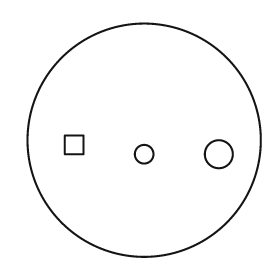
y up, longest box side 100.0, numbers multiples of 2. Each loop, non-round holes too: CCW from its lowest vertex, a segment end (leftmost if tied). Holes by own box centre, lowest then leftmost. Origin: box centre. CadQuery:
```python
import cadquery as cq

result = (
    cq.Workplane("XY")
    .moveTo(0.0, 0.0)
    .circle(50.0)
    .moveTo(0.0, -6.0)
    .circle(4.0)
    .moveTo(32.0, -6.0)
    .circle(6.0)
    .moveTo(-34.0, -6.0)
    .lineTo(-26.0, -6.0)
    .lineTo(-26.0, 2.0)
    .lineTo(-34.0, 2.0)
    .close()
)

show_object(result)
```